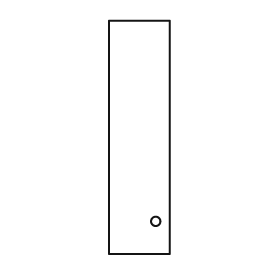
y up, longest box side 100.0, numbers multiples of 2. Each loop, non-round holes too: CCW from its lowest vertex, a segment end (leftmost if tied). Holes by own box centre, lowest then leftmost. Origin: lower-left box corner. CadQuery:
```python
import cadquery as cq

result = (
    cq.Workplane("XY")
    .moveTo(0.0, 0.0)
    .lineTo(26.0, 0.0)
    .lineTo(26.0, 100.0)
    .lineTo(0.0, 100.0)
    .close()
    .moveTo(20.0, 14.0)
    .circle(2.0)
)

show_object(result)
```